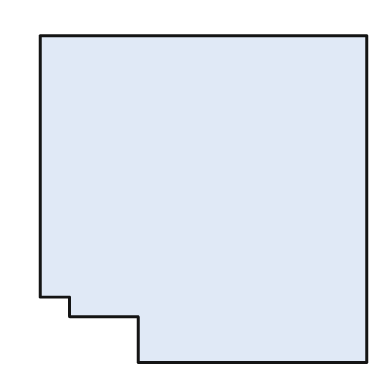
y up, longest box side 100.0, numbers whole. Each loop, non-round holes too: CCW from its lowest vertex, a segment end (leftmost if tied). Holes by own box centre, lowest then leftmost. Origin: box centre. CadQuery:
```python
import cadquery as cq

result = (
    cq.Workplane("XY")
    .moveTo(-20.0, -50.0)
    .lineTo(50.0, -50.0)
    .lineTo(50.0, 50.0)
    .lineTo(-50.0, 50.0)
    .lineTo(-50.0, -30.0)
    .lineTo(-41.0, -30.0)
    .lineTo(-41.0, -36.0)
    .lineTo(-20.0, -36.0)
    .close()
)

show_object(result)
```